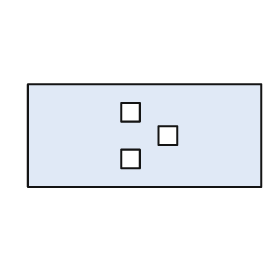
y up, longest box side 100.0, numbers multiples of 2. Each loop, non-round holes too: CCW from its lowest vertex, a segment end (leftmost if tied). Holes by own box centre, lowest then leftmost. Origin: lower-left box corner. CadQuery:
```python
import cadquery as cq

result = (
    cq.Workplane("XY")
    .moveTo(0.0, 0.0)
    .lineTo(100.0, 0.0)
    .lineTo(100.0, 44.0)
    .lineTo(0.0, 44.0)
    .close()
    .moveTo(40.0, 8.0)
    .lineTo(48.0, 8.0)
    .lineTo(48.0, 16.0)
    .lineTo(40.0, 16.0)
    .close()
    .moveTo(56.0, 18.0)
    .lineTo(64.0, 18.0)
    .lineTo(64.0, 26.0)
    .lineTo(56.0, 26.0)
    .close()
    .moveTo(40.0, 28.0)
    .lineTo(48.0, 28.0)
    .lineTo(48.0, 36.0)
    .lineTo(40.0, 36.0)
    .close()
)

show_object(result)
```